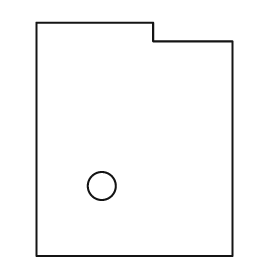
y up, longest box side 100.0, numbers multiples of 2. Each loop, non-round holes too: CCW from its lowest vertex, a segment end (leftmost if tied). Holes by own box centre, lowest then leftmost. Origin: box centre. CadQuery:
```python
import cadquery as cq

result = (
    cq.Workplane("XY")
    .moveTo(-42.0, -50.0)
    .lineTo(42.0, -50.0)
    .lineTo(42.0, 42.0)
    .lineTo(8.0, 42.0)
    .lineTo(8.0, 50.0)
    .lineTo(-42.0, 50.0)
    .close()
    .moveTo(-14.0, -20.0)
    .circle(6.0)
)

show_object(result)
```